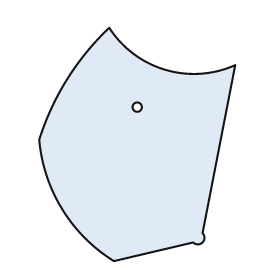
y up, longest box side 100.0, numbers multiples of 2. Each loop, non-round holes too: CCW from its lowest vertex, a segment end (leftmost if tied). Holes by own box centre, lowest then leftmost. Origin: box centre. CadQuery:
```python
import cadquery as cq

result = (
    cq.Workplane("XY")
    .moveTo(-10.0, -50.0)
    .lineTo(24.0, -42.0)
    .threePointArc((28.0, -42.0), (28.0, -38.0))
    .lineTo(42.0, 34.0)
    .threePointArc((12.0, 32.0), (-12.0, 50.0))
    .threePointArc((-30.0, 28.0), (-42.0, 2.0))
    .threePointArc((-32.0, -28.0), (-10.0, -50.0))
    .close()
    .moveTo(0.0, 16.0)
    .circle(2.0)
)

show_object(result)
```